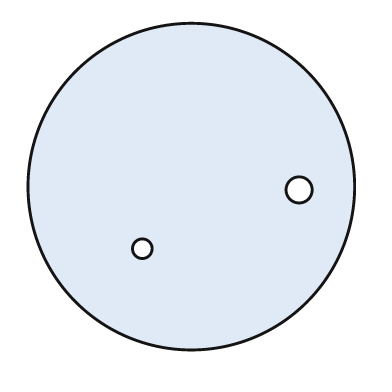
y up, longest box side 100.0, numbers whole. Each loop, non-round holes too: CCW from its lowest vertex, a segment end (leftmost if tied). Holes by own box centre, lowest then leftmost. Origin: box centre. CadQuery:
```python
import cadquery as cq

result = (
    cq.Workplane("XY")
    .moveTo(0.0, 0.0)
    .circle(50.0)
    .moveTo(-15.0, -19.0)
    .circle(3.0)
    .moveTo(33.0, -1.0)
    .circle(4.0)
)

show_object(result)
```